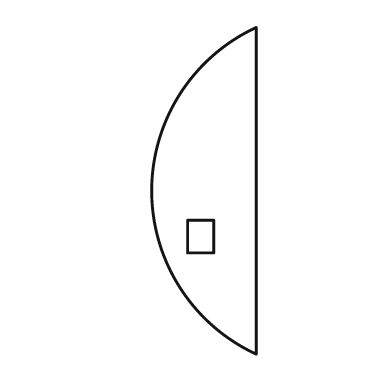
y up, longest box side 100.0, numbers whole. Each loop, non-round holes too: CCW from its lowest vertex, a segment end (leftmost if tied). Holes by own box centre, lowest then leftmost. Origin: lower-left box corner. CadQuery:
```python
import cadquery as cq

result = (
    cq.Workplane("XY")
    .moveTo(32.0, 0.0)
    .lineTo(32.0, 100.0)
    .threePointArc((0.0, 50.0), (32.0, 0.0))
    .close()
    .moveTo(11.0, 31.0)
    .lineTo(19.0, 31.0)
    .lineTo(19.0, 41.0)
    .lineTo(11.0, 41.0)
    .close()
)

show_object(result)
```